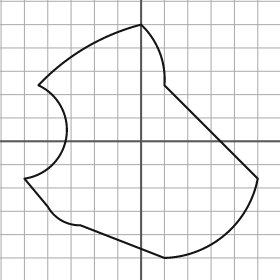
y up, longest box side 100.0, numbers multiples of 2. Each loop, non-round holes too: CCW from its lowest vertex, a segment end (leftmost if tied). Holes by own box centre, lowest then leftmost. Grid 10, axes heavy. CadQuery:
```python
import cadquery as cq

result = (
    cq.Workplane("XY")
    .moveTo(10.0, -50.0)
    .threePointArc((36.0, -40.0), (50.0, -16.0))
    .lineTo(10.0, 24.0)
    .threePointArc((8.0, 38.0), (0.0, 50.0))
    .threePointArc((-24.0, 40.0), (-44.0, 24.0))
    .threePointArc((-32.0, 2.0), (-50.0, -16.0))
    .lineTo(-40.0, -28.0)
    .threePointArc((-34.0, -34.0), (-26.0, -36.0))
    .close()
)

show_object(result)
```